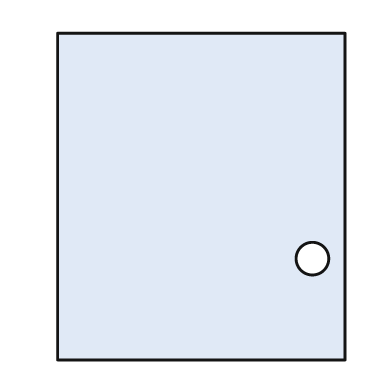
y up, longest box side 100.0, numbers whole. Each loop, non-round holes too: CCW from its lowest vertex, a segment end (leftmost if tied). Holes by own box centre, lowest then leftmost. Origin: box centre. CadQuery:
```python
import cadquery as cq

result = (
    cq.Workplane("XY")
    .moveTo(-44.0, -50.0)
    .lineTo(44.0, -50.0)
    .lineTo(44.0, 50.0)
    .lineTo(-44.0, 50.0)
    .close()
    .moveTo(34.0, -19.0)
    .circle(5.0)
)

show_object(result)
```